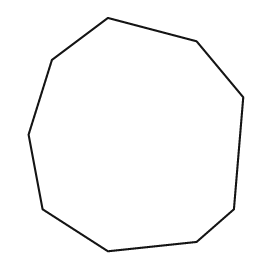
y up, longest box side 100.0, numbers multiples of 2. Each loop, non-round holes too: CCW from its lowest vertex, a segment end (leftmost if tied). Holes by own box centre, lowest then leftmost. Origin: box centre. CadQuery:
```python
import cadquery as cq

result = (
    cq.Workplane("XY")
    .moveTo(-12.0, -50.0)
    .lineTo(26.0, -46.0)
    .lineTo(42.0, -32.0)
    .lineTo(46.0, 16.0)
    .lineTo(26.0, 40.0)
    .lineTo(-12.0, 50.0)
    .lineTo(-36.0, 32.0)
    .lineTo(-46.0, 0.0)
    .lineTo(-40.0, -32.0)
    .close()
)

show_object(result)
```